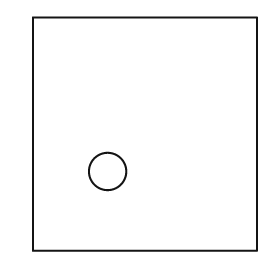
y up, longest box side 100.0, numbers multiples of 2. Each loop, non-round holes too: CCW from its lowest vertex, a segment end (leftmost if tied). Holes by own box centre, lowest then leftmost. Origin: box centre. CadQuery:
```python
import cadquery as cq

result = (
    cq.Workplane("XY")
    .moveTo(-48.0, -50.0)
    .lineTo(48.0, -50.0)
    .lineTo(48.0, 50.0)
    .lineTo(-48.0, 50.0)
    .close()
    .moveTo(-16.0, -16.0)
    .circle(8.0)
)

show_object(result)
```